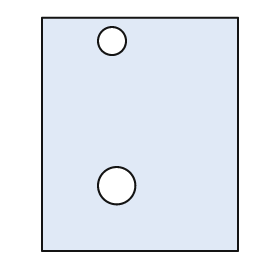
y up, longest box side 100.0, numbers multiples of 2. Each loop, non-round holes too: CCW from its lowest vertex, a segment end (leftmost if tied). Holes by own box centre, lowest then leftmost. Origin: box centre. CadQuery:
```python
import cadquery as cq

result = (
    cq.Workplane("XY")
    .moveTo(-42.0, -50.0)
    .lineTo(42.0, -50.0)
    .lineTo(42.0, 50.0)
    .lineTo(-42.0, 50.0)
    .close()
    .moveTo(-10.0, -22.0)
    .circle(8.0)
    .moveTo(-12.0, 40.0)
    .circle(6.0)
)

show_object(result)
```